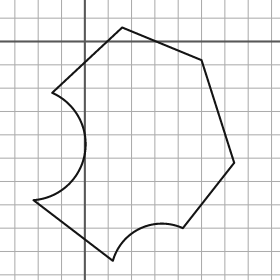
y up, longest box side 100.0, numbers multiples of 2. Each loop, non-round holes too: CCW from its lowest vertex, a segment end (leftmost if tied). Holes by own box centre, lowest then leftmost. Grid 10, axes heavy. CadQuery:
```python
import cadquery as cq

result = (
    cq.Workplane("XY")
    .moveTo(12.0, -94.0)
    .threePointArc((24.0, -80.0), (42.0, -80.0))
    .lineTo(64.0, -52.0)
    .lineTo(50.0, -8.0)
    .lineTo(16.0, 6.0)
    .lineTo(-14.0, -22.0)
    .threePointArc((0.0, -48.0), (-22.0, -68.0))
    .close()
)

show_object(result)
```